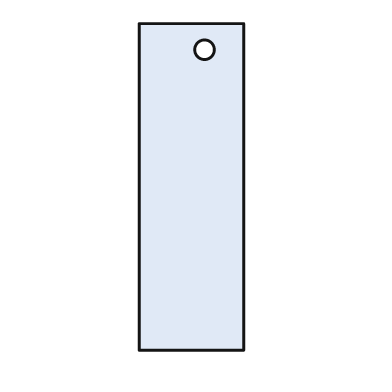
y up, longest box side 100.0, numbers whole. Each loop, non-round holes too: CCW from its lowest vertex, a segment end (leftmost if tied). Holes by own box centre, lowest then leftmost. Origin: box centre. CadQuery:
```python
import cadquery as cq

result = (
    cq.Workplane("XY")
    .moveTo(-16.0, -50.0)
    .lineTo(16.0, -50.0)
    .lineTo(16.0, 50.0)
    .lineTo(-16.0, 50.0)
    .close()
    .moveTo(4.0, 42.0)
    .circle(3.0)
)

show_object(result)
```